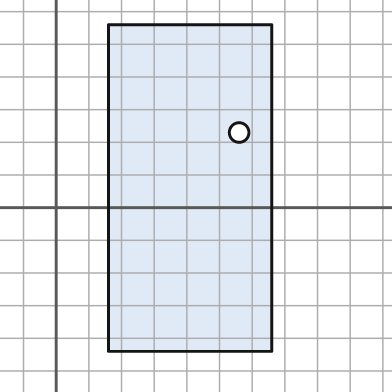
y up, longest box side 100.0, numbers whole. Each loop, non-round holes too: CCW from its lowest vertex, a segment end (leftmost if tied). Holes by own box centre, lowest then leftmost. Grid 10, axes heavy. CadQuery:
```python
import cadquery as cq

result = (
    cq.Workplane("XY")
    .moveTo(16.0, -44.0)
    .lineTo(66.0, -44.0)
    .lineTo(66.0, 56.0)
    .lineTo(16.0, 56.0)
    .close()
    .moveTo(56.0, 23.0)
    .circle(3.0)
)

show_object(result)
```